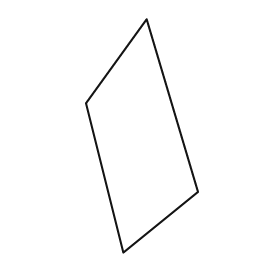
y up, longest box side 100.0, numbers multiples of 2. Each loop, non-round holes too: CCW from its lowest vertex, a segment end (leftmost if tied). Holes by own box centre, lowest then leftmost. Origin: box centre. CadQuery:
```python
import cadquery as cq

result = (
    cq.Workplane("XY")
    .moveTo(-8.0, -50.0)
    .lineTo(24.0, -24.0)
    .lineTo(2.0, 50.0)
    .lineTo(-24.0, 14.0)
    .close()
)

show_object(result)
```